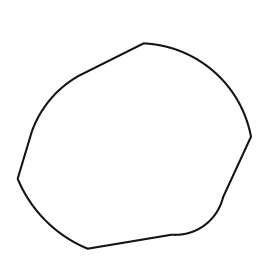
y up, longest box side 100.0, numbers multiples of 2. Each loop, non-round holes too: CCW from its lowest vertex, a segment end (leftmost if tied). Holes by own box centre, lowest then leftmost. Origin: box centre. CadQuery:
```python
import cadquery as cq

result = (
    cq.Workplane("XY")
    .moveTo(-20.0, -44.0)
    .lineTo(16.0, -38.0)
    .threePointArc((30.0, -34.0), (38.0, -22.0))
    .lineTo(50.0, 4.0)
    .threePointArc((34.0, 32.0), (4.0, 44.0))
    .lineTo(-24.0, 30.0)
    .threePointArc((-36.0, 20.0), (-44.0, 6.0))
    .lineTo(-50.0, -14.0)
    .threePointArc((-38.0, -32.0), (-20.0, -44.0))
    .close()
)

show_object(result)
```